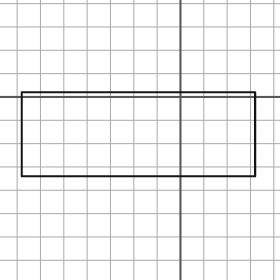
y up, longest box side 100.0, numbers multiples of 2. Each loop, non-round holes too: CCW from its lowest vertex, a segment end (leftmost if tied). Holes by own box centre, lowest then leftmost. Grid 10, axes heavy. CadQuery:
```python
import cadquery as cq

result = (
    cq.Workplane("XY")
    .moveTo(-68.0, -34.0)
    .lineTo(32.0, -34.0)
    .lineTo(32.0, 2.0)
    .lineTo(-68.0, 2.0)
    .close()
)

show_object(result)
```